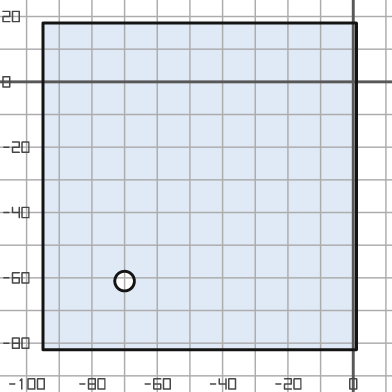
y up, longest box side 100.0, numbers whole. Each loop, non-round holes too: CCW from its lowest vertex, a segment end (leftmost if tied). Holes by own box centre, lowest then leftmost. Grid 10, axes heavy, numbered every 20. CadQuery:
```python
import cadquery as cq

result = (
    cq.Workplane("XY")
    .moveTo(-95.0, -82.0)
    .lineTo(1.0, -82.0)
    .lineTo(1.0, 18.0)
    .lineTo(-95.0, 18.0)
    .close()
    .moveTo(-70.0, -61.0)
    .circle(3.0)
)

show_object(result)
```